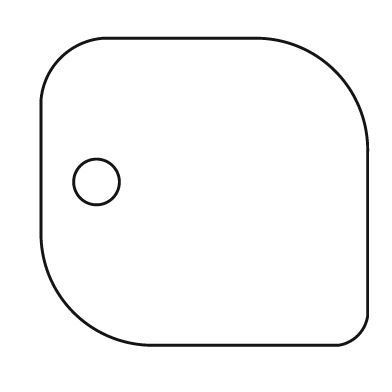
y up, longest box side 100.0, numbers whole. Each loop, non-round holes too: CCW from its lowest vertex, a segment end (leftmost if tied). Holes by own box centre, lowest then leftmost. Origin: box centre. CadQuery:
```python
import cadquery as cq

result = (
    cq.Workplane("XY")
    .moveTo(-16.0, -47.0)
    .lineTo(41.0, -47.0)
    .threePointArc((47.0, -44.0), (50.0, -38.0))
    .lineTo(50.0, 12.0)
    .threePointArc((40.0, 37.0), (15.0, 47.0))
    .lineTo(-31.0, 47.0)
    .threePointArc((-44.0, 41.0), (-50.0, 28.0))
    .lineTo(-50.0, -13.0)
    .threePointArc((-40.0, -37.0), (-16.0, -47.0))
    .close()
    .moveTo(-33.0, 3.0)
    .circle(7.0)
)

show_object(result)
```